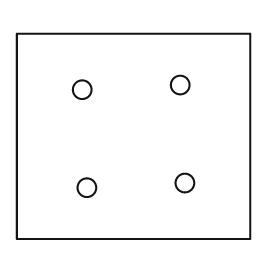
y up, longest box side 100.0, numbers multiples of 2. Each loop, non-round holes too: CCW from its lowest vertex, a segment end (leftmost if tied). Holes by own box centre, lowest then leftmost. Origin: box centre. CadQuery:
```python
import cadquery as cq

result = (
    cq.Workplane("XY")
    .moveTo(-50.0, -44.0)
    .lineTo(50.0, -44.0)
    .lineTo(50.0, 44.0)
    .lineTo(-50.0, 44.0)
    .close()
    .moveTo(-20.0, -22.0)
    .circle(4.0)
    .moveTo(22.0, -20.0)
    .circle(4.0)
    .moveTo(-22.0, 20.0)
    .circle(4.0)
    .moveTo(20.0, 22.0)
    .circle(4.0)
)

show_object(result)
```